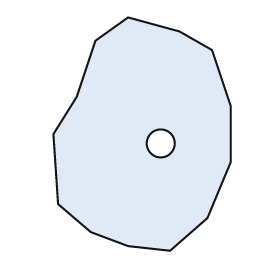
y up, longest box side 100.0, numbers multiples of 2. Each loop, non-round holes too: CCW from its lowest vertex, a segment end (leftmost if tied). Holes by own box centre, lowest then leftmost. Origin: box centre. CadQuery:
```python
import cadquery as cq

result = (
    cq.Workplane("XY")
    .moveTo(12.0, -50.0)
    .lineTo(28.0, -36.0)
    .lineTo(38.0, -12.0)
    .lineTo(38.0, 12.0)
    .lineTo(30.0, 36.0)
    .lineTo(16.0, 44.0)
    .lineTo(-6.0, 50.0)
    .lineTo(-20.0, 40.0)
    .lineTo(-28.0, 16.0)
    .lineTo(-38.0, 0.0)
    .lineTo(-36.0, -30.0)
    .lineTo(-22.0, -42.0)
    .lineTo(-6.0, -48.0)
    .close()
    .moveTo(8.0, -4.0)
    .circle(6.0)
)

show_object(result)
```